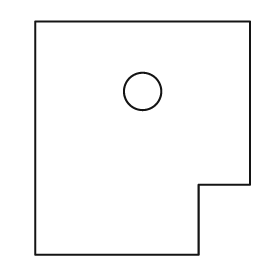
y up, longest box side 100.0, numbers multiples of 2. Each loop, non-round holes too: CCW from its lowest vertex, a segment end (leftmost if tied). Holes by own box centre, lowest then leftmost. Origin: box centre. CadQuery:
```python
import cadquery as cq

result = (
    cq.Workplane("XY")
    .moveTo(-46.0, -50.0)
    .lineTo(24.0, -50.0)
    .lineTo(24.0, -20.0)
    .lineTo(46.0, -20.0)
    .lineTo(46.0, 50.0)
    .lineTo(-46.0, 50.0)
    .close()
    .moveTo(0.0, 20.0)
    .circle(8.0)
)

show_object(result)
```